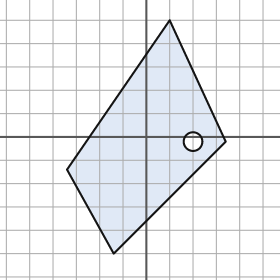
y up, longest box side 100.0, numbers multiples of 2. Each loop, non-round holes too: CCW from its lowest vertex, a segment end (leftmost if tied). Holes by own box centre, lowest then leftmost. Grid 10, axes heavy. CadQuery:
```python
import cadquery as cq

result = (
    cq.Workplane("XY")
    .moveTo(-14.0, -50.0)
    .lineTo(34.0, -2.0)
    .lineTo(10.0, 50.0)
    .lineTo(-34.0, -14.0)
    .close()
    .moveTo(20.0, -2.0)
    .circle(4.0)
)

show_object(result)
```